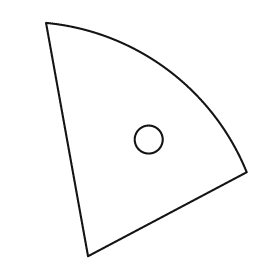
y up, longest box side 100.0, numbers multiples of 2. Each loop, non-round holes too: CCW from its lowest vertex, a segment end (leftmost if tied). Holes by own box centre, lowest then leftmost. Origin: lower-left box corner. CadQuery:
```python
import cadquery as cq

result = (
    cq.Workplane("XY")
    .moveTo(18.0, 0.0)
    .lineTo(86.0, 36.0)
    .threePointArc((52.0, 80.0), (0.0, 100.0))
    .close()
    .moveTo(44.0, 50.0)
    .circle(6.0)
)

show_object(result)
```